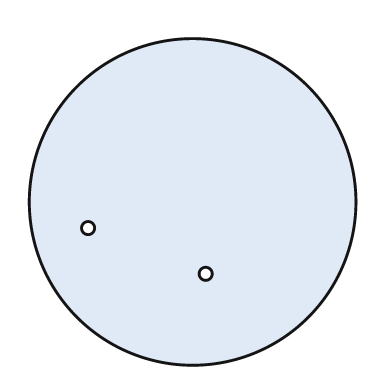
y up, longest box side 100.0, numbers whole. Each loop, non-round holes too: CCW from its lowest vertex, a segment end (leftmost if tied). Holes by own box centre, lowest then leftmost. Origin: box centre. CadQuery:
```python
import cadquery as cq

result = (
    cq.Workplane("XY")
    .moveTo(0.0, 0.0)
    .circle(50.0)
    .moveTo(4.0, -22.0)
    .circle(2.0)
    .moveTo(-32.0, -8.0)
    .circle(2.0)
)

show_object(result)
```